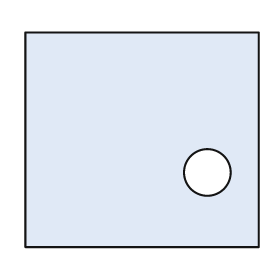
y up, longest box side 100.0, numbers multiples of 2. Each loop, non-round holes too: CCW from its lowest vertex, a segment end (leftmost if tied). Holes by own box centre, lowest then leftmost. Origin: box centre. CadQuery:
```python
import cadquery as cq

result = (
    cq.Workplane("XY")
    .moveTo(-50.0, -46.0)
    .lineTo(50.0, -46.0)
    .lineTo(50.0, 46.0)
    .lineTo(-50.0, 46.0)
    .close()
    .moveTo(28.0, -14.0)
    .circle(10.0)
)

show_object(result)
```